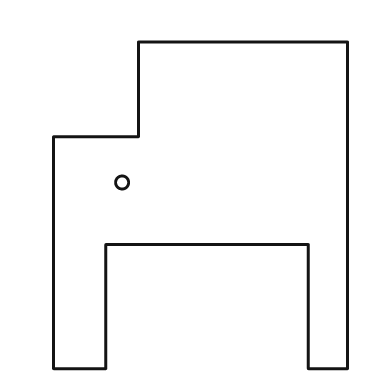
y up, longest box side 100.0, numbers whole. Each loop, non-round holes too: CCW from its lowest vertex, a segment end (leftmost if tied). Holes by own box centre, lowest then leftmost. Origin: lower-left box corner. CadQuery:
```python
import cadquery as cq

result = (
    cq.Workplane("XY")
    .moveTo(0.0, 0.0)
    .lineTo(16.0, 0.0)
    .lineTo(16.0, 38.0)
    .lineTo(78.0, 38.0)
    .lineTo(78.0, 0.0)
    .lineTo(90.0, 0.0)
    .lineTo(90.0, 100.0)
    .lineTo(26.0, 100.0)
    .lineTo(26.0, 71.0)
    .lineTo(0.0, 71.0)
    .close()
    .moveTo(21.0, 57.0)
    .circle(2.0)
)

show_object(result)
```